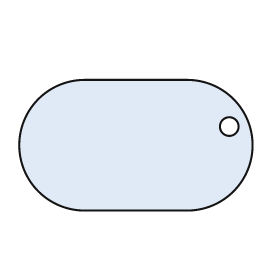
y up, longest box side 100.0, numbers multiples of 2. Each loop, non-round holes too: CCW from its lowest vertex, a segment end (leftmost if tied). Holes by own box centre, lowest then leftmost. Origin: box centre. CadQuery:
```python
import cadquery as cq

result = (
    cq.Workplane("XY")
    .moveTo(-22.0, -28.0)
    .lineTo(22.0, -28.0)
    .threePointArc((50.0, 0.0), (22.0, 28.0))
    .lineTo(-22.0, 28.0)
    .threePointArc((-50.0, 0.0), (-22.0, -28.0))
    .close()
    .moveTo(40.0, 8.0)
    .circle(4.0)
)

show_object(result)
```